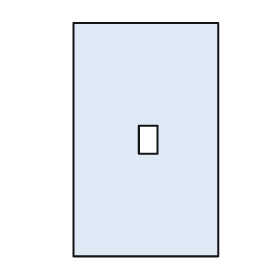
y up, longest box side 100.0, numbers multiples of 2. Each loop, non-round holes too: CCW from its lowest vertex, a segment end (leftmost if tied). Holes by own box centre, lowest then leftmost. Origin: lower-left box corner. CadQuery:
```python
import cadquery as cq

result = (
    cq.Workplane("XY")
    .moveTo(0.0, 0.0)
    .lineTo(62.0, 0.0)
    .lineTo(62.0, 100.0)
    .lineTo(0.0, 100.0)
    .close()
    .moveTo(28.0, 44.0)
    .lineTo(36.0, 44.0)
    .lineTo(36.0, 56.0)
    .lineTo(28.0, 56.0)
    .close()
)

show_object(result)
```